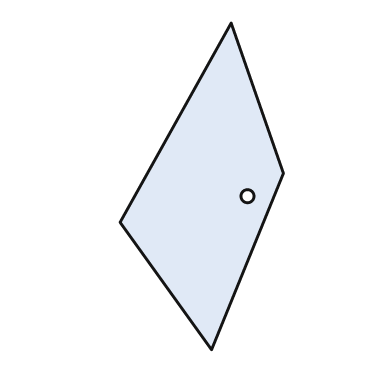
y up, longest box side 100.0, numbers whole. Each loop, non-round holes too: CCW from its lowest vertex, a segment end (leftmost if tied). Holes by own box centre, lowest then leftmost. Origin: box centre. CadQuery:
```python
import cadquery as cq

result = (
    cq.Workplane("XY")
    .moveTo(3.0, -50.0)
    .lineTo(25.0, 4.0)
    .lineTo(9.0, 50.0)
    .lineTo(-25.0, -11.0)
    .close()
    .moveTo(14.0, -3.0)
    .circle(2.0)
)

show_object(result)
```